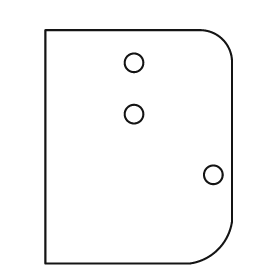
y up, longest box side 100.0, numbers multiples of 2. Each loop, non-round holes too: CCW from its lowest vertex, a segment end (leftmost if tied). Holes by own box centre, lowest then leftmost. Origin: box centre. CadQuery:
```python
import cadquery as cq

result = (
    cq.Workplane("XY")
    .moveTo(-40.0, -50.0)
    .lineTo(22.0, -50.0)
    .threePointArc((34.0, -44.0), (40.0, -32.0))
    .lineTo(40.0, 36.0)
    .threePointArc((36.0, 46.0), (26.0, 50.0))
    .lineTo(-40.0, 50.0)
    .close()
    .moveTo(32.0, -12.0)
    .circle(4.0)
    .moveTo(-2.0, 14.0)
    .circle(4.0)
    .moveTo(-2.0, 36.0)
    .circle(4.0)
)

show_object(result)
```